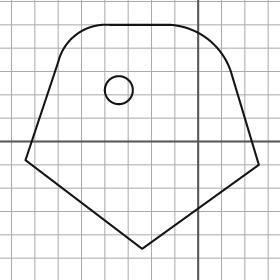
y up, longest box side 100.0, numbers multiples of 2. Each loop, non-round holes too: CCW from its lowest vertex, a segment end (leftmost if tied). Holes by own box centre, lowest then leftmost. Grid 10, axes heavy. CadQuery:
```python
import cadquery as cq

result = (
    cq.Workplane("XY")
    .moveTo(-24.0, -46.0)
    .lineTo(26.0, -10.0)
    .lineTo(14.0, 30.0)
    .threePointArc((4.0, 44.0), (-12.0, 50.0))
    .lineTo(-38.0, 50.0)
    .threePointArc((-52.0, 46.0), (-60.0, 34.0))
    .lineTo(-74.0, -8.0)
    .close()
    .moveTo(-34.0, 22.0)
    .circle(6.0)
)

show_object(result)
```